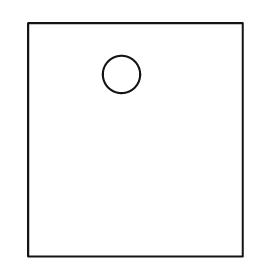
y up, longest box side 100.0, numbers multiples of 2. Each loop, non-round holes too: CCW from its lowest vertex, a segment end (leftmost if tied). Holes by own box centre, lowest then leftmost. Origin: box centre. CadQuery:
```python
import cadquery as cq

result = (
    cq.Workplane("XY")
    .moveTo(-46.0, -50.0)
    .lineTo(46.0, -50.0)
    .lineTo(46.0, 50.0)
    .lineTo(-46.0, 50.0)
    .close()
    .moveTo(-6.0, 28.0)
    .circle(8.0)
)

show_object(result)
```